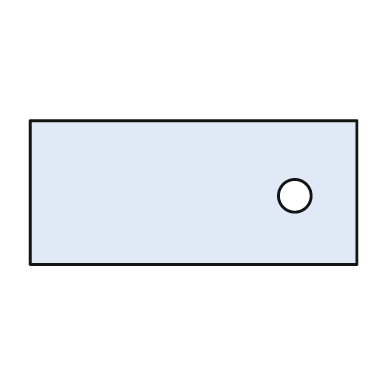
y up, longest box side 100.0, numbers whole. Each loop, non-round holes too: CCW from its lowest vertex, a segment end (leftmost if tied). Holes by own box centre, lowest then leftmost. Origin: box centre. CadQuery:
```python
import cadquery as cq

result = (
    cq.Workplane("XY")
    .moveTo(-50.0, -22.0)
    .lineTo(50.0, -22.0)
    .lineTo(50.0, 22.0)
    .lineTo(-50.0, 22.0)
    .close()
    .moveTo(31.0, -1.0)
    .circle(5.0)
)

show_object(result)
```